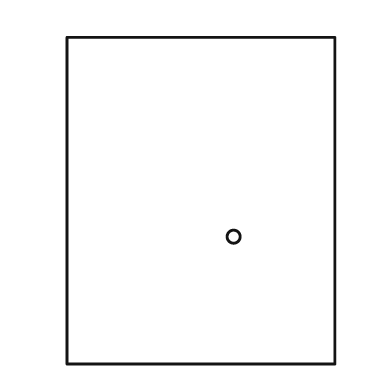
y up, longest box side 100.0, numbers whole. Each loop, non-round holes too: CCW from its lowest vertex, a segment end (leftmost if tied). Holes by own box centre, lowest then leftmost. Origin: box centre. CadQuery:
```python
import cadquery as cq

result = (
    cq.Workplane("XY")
    .moveTo(-41.0, -50.0)
    .lineTo(41.0, -50.0)
    .lineTo(41.0, 50.0)
    .lineTo(-41.0, 50.0)
    .close()
    .moveTo(10.0, -11.0)
    .circle(2.0)
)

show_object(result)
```